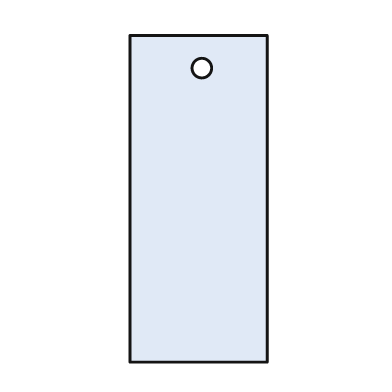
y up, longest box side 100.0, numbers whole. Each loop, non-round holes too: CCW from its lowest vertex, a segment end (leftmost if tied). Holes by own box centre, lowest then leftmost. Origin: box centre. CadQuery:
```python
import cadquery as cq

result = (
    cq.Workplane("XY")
    .moveTo(-21.0, -50.0)
    .lineTo(21.0, -50.0)
    .lineTo(21.0, 50.0)
    .lineTo(-21.0, 50.0)
    .close()
    .moveTo(1.0, 40.0)
    .circle(3.0)
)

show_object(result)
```